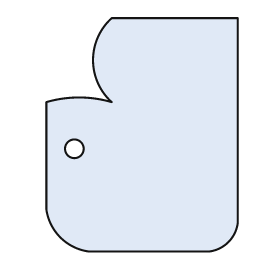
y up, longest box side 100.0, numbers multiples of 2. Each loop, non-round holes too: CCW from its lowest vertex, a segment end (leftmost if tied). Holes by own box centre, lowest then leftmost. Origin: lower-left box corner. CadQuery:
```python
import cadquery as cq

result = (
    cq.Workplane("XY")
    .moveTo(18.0, 0.0)
    .lineTo(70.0, 0.0)
    .threePointArc((78.0, 4.0), (82.0, 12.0))
    .lineTo(82.0, 100.0)
    .lineTo(28.0, 100.0)
    .threePointArc((20.0, 82.0), (28.0, 64.0))
    .threePointArc((14.0, 66.0), (0.0, 64.0))
    .lineTo(0.0, 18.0)
    .threePointArc((6.0, 6.0), (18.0, 0.0))
    .close()
    .moveTo(12.0, 44.0)
    .circle(4.0)
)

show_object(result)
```